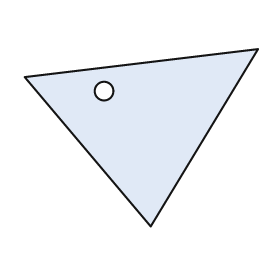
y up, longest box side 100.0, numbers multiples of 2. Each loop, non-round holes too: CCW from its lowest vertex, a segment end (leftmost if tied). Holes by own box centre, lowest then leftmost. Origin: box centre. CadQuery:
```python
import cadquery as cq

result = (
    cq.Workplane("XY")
    .moveTo(4.0, -38.0)
    .lineTo(50.0, 38.0)
    .lineTo(-50.0, 26.0)
    .close()
    .moveTo(-16.0, 20.0)
    .circle(4.0)
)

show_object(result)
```